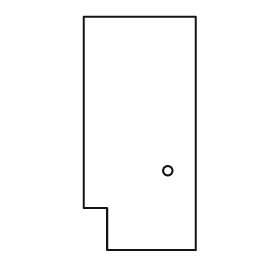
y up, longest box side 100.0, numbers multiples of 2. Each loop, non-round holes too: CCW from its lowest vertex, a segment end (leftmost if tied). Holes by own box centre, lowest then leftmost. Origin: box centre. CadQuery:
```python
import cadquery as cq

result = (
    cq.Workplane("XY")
    .moveTo(-14.0, -50.0)
    .lineTo(24.0, -50.0)
    .lineTo(24.0, 50.0)
    .lineTo(-24.0, 50.0)
    .lineTo(-24.0, -32.0)
    .lineTo(-14.0, -32.0)
    .close()
    .moveTo(12.0, -16.0)
    .circle(2.0)
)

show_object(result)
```